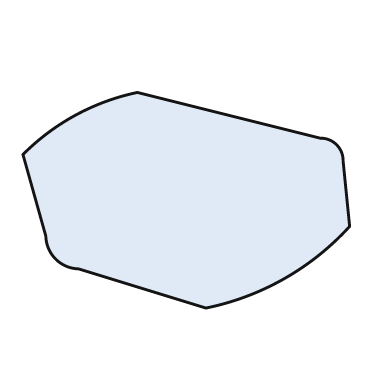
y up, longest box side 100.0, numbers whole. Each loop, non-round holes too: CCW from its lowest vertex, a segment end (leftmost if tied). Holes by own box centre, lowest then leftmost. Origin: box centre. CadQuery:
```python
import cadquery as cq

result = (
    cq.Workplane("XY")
    .moveTo(6.0, -33.0)
    .threePointArc((30.0, -24.0), (50.0, -8.0))
    .lineTo(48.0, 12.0)
    .threePointArc((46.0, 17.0), (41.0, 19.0))
    .lineTo(-15.0, 33.0)
    .threePointArc((-34.0, 26.0), (-50.0, 14.0))
    .lineTo(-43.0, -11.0)
    .threePointArc((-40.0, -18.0), (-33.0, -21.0))
    .close()
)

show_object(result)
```